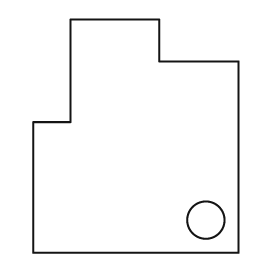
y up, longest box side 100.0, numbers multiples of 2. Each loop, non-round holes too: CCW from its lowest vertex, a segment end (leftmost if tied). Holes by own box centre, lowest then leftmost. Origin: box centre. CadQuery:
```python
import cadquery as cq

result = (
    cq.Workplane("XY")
    .moveTo(-44.0, -50.0)
    .lineTo(44.0, -50.0)
    .lineTo(44.0, 32.0)
    .lineTo(10.0, 32.0)
    .lineTo(10.0, 50.0)
    .lineTo(-28.0, 50.0)
    .lineTo(-28.0, 6.0)
    .lineTo(-44.0, 6.0)
    .close()
    .moveTo(30.0, -36.0)
    .circle(8.0)
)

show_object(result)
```